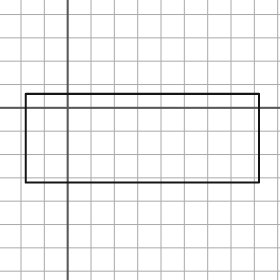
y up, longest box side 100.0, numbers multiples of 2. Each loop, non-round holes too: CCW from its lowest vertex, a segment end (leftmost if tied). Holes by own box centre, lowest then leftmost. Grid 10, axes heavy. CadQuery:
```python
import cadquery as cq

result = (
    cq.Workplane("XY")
    .moveTo(-18.0, -32.0)
    .lineTo(82.0, -32.0)
    .lineTo(82.0, 6.0)
    .lineTo(-18.0, 6.0)
    .close()
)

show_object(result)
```